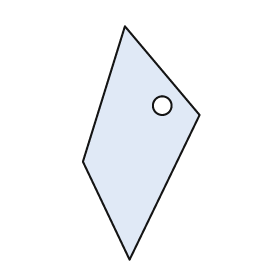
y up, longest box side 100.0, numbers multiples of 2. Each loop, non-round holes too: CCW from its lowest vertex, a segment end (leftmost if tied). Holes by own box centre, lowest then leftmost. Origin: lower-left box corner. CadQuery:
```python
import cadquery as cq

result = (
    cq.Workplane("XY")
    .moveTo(20.0, 0.0)
    .lineTo(50.0, 62.0)
    .lineTo(18.0, 100.0)
    .lineTo(0.0, 42.0)
    .close()
    .moveTo(34.0, 66.0)
    .circle(4.0)
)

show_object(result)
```